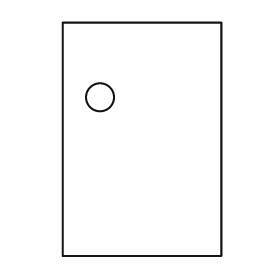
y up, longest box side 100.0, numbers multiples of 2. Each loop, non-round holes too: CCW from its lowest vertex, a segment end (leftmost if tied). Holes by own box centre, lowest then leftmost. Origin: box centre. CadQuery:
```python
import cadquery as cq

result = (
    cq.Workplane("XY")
    .moveTo(-34.0, -50.0)
    .lineTo(34.0, -50.0)
    .lineTo(34.0, 50.0)
    .lineTo(-34.0, 50.0)
    .close()
    .moveTo(-18.0, 18.0)
    .circle(6.0)
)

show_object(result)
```